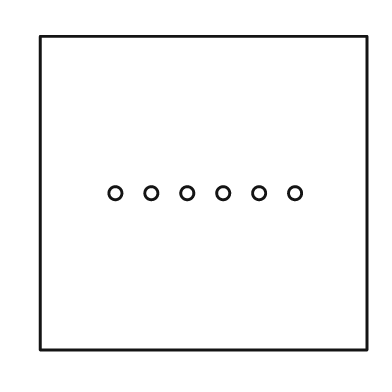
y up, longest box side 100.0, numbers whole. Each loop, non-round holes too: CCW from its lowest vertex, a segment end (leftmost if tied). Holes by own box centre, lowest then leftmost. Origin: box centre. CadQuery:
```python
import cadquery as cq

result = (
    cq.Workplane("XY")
    .moveTo(-50.0, -48.0)
    .lineTo(50.0, -48.0)
    .lineTo(50.0, 48.0)
    .lineTo(-50.0, 48.0)
    .close()
    .moveTo(-27.0, 0.0)
    .circle(2.0)
    .moveTo(-16.0, 0.0)
    .circle(2.0)
    .moveTo(-5.0, 0.0)
    .circle(2.0)
    .moveTo(6.0, 0.0)
    .circle(2.0)
    .moveTo(17.0, 0.0)
    .circle(2.0)
    .moveTo(28.0, 0.0)
    .circle(2.0)
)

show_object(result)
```